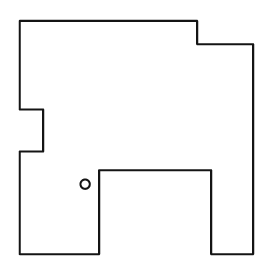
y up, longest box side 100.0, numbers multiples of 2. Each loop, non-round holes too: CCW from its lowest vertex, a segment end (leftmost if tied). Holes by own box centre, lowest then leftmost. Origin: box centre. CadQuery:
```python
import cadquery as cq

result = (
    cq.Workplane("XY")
    .moveTo(-50.0, -50.0)
    .lineTo(-16.0, -50.0)
    .lineTo(-16.0, -14.0)
    .lineTo(32.0, -14.0)
    .lineTo(32.0, -50.0)
    .lineTo(50.0, -50.0)
    .lineTo(50.0, 40.0)
    .lineTo(26.0, 40.0)
    .lineTo(26.0, 50.0)
    .lineTo(-50.0, 50.0)
    .lineTo(-50.0, 12.0)
    .lineTo(-40.0, 12.0)
    .lineTo(-40.0, -6.0)
    .lineTo(-50.0, -6.0)
    .close()
    .moveTo(-22.0, -20.0)
    .circle(2.0)
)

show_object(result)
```